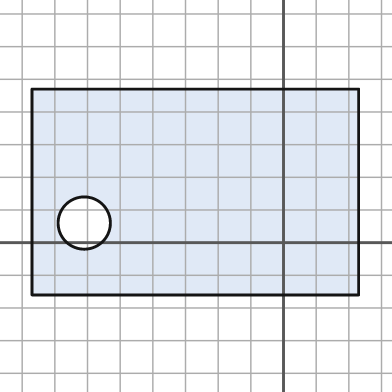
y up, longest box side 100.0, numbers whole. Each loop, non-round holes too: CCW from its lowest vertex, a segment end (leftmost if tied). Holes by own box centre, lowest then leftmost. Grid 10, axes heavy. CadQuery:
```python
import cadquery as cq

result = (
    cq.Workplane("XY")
    .moveTo(-77.0, -16.0)
    .lineTo(23.0, -16.0)
    .lineTo(23.0, 47.0)
    .lineTo(-77.0, 47.0)
    .close()
    .moveTo(-61.0, 6.0)
    .circle(8.0)
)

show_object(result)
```